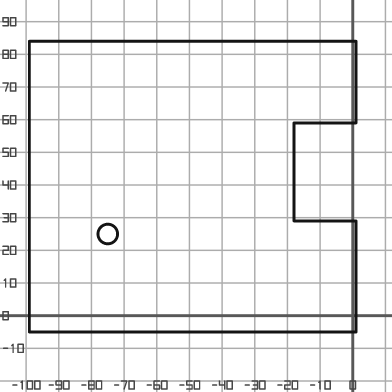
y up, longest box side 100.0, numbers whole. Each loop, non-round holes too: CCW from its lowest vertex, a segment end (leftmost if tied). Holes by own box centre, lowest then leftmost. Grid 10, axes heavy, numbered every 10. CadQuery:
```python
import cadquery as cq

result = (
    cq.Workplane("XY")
    .moveTo(-99.0, -5.0)
    .lineTo(1.0, -5.0)
    .lineTo(1.0, 29.0)
    .lineTo(-18.0, 29.0)
    .lineTo(-18.0, 59.0)
    .lineTo(1.0, 59.0)
    .lineTo(1.0, 84.0)
    .lineTo(-99.0, 84.0)
    .close()
    .moveTo(-75.0, 25.0)
    .circle(3.0)
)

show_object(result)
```